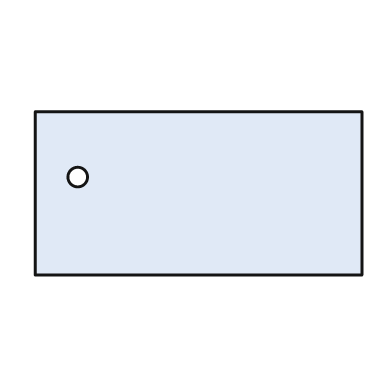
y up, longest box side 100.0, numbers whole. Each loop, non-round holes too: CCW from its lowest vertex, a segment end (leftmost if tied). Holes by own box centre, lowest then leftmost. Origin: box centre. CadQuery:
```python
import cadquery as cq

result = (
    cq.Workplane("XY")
    .moveTo(-50.0, -25.0)
    .lineTo(50.0, -25.0)
    .lineTo(50.0, 25.0)
    .lineTo(-50.0, 25.0)
    .close()
    .moveTo(-37.0, 5.0)
    .circle(3.0)
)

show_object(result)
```